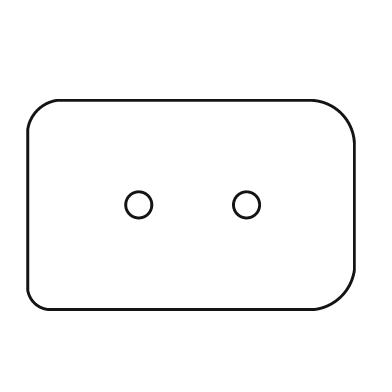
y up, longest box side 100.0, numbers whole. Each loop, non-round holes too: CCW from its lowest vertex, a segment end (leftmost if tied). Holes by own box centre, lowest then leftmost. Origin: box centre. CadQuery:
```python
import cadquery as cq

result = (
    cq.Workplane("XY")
    .moveTo(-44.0, -32.0)
    .lineTo(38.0, -32.0)
    .threePointArc((46.0, -28.0), (50.0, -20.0))
    .lineTo(50.0, 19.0)
    .threePointArc((46.0, 28.0), (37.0, 32.0))
    .lineTo(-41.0, 32.0)
    .threePointArc((-47.0, 29.0), (-50.0, 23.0))
    .lineTo(-50.0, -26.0)
    .threePointArc((-48.0, -30.0), (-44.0, -32.0))
    .close()
    .moveTo(-16.0, 0.0)
    .circle(4.0)
    .moveTo(17.0, 0.0)
    .circle(4.0)
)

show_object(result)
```